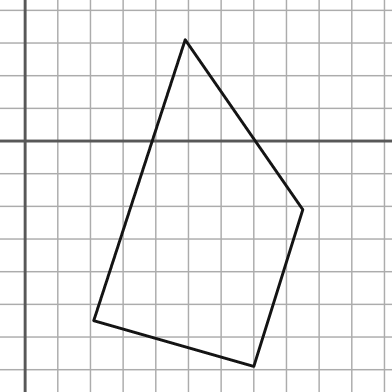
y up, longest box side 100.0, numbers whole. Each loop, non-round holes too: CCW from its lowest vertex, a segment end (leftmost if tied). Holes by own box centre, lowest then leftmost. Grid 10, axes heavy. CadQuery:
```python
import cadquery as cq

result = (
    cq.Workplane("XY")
    .moveTo(70.0, -69.0)
    .lineTo(85.0, -21.0)
    .lineTo(49.0, 31.0)
    .lineTo(21.0, -55.0)
    .close()
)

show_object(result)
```